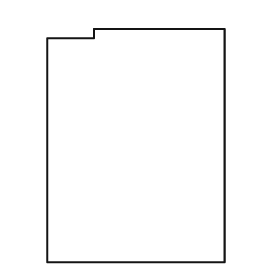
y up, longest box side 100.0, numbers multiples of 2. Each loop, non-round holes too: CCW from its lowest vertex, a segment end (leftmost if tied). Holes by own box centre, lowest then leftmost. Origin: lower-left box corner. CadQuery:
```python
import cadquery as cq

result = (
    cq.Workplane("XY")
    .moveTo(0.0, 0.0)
    .lineTo(76.0, 0.0)
    .lineTo(76.0, 100.0)
    .lineTo(20.0, 100.0)
    .lineTo(20.0, 96.0)
    .lineTo(0.0, 96.0)
    .close()
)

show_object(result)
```